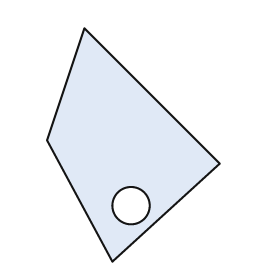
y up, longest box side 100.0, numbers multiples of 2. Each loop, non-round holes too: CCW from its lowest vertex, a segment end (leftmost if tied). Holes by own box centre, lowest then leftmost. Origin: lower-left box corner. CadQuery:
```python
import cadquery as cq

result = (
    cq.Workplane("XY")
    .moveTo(28.0, 0.0)
    .lineTo(74.0, 42.0)
    .lineTo(16.0, 100.0)
    .lineTo(0.0, 52.0)
    .close()
    .moveTo(36.0, 24.0)
    .circle(8.0)
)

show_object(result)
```